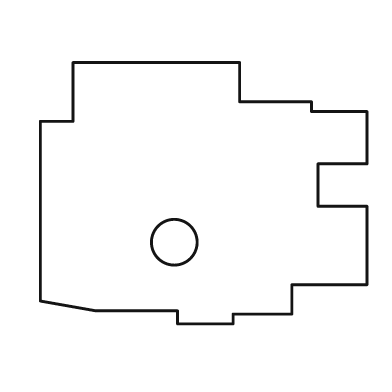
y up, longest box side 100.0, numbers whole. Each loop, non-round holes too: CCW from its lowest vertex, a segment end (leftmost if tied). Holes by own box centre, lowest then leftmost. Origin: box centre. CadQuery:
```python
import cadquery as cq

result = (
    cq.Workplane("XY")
    .moveTo(-8.0, -40.0)
    .lineTo(9.0, -40.0)
    .lineTo(9.0, -37.0)
    .lineTo(27.0, -37.0)
    .lineTo(27.0, -28.0)
    .lineTo(50.0, -28.0)
    .lineTo(50.0, -4.0)
    .lineTo(35.0, -4.0)
    .lineTo(35.0, 9.0)
    .lineTo(50.0, 9.0)
    .lineTo(50.0, 25.0)
    .lineTo(33.0, 25.0)
    .lineTo(33.0, 28.0)
    .lineTo(11.0, 28.0)
    .lineTo(11.0, 40.0)
    .lineTo(-40.0, 40.0)
    .lineTo(-40.0, 22.0)
    .lineTo(-50.0, 22.0)
    .lineTo(-50.0, -33.0)
    .lineTo(-33.0, -36.0)
    .lineTo(-8.0, -36.0)
    .close()
    .moveTo(-9.0, -15.0)
    .circle(7.0)
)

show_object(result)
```